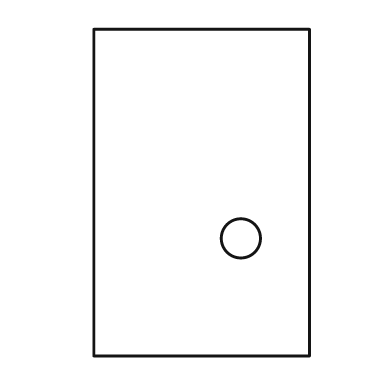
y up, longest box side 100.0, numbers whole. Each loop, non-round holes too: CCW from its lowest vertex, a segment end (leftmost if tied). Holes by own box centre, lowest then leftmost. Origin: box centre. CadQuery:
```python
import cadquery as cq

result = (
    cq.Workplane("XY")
    .moveTo(-33.0, -50.0)
    .lineTo(33.0, -50.0)
    .lineTo(33.0, 50.0)
    .lineTo(-33.0, 50.0)
    .close()
    .moveTo(12.0, -14.0)
    .circle(6.0)
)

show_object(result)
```